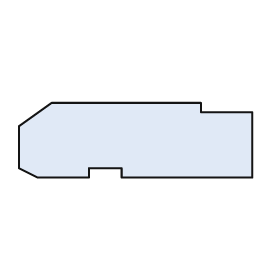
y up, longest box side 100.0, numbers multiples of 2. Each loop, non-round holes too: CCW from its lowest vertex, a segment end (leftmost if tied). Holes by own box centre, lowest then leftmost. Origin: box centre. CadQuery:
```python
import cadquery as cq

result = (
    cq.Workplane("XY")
    .moveTo(-42.0, -16.0)
    .lineTo(-20.0, -16.0)
    .lineTo(-20.0, -12.0)
    .lineTo(-6.0, -12.0)
    .lineTo(-6.0, -16.0)
    .lineTo(50.0, -16.0)
    .lineTo(50.0, 12.0)
    .lineTo(28.0, 12.0)
    .lineTo(28.0, 16.0)
    .lineTo(-36.0, 16.0)
    .lineTo(-50.0, 6.0)
    .lineTo(-50.0, -12.0)
    .close()
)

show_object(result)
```